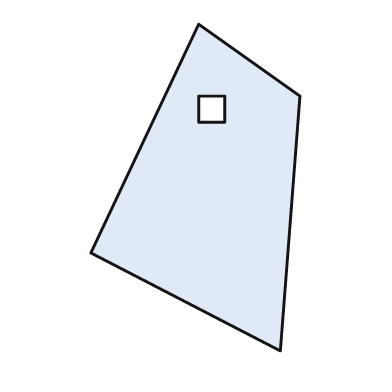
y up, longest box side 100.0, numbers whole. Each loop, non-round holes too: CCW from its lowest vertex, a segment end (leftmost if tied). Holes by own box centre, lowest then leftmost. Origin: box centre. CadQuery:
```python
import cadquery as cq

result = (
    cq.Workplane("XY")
    .moveTo(26.0, -50.0)
    .lineTo(32.0, 28.0)
    .lineTo(1.0, 50.0)
    .lineTo(-32.0, -20.0)
    .close()
    .moveTo(1.0, 20.0)
    .lineTo(9.0, 20.0)
    .lineTo(9.0, 28.0)
    .lineTo(1.0, 28.0)
    .close()
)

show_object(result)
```